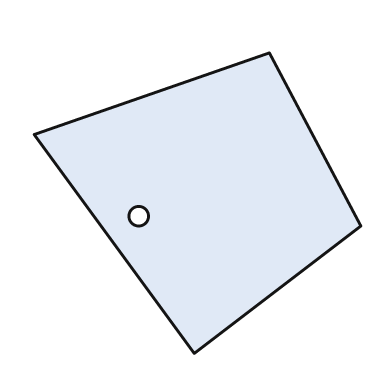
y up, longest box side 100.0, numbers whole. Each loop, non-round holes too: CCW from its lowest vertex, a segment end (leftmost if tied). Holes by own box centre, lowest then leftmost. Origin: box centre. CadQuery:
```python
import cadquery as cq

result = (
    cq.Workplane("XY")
    .moveTo(-1.0, -46.0)
    .lineTo(50.0, -7.0)
    .lineTo(22.0, 46.0)
    .lineTo(-50.0, 21.0)
    .close()
    .moveTo(-18.0, -4.0)
    .circle(3.0)
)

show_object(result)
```